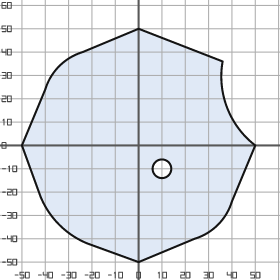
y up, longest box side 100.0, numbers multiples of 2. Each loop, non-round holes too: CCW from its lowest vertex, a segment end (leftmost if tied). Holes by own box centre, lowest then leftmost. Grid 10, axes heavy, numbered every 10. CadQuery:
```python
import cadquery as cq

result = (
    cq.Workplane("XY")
    .moveTo(0.0, -50.0)
    .lineTo(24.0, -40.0)
    .threePointArc((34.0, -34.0), (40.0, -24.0))
    .lineTo(50.0, 0.0)
    .threePointArc((38.0, 16.0), (36.0, 36.0))
    .lineTo(0.0, 50.0)
    .lineTo(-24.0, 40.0)
    .threePointArc((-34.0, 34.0), (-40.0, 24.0))
    .lineTo(-50.0, 0.0)
    .lineTo(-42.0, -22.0)
    .threePointArc((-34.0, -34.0), (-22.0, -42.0))
    .close()
    .moveTo(10.0, -10.0)
    .circle(4.0)
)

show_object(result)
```